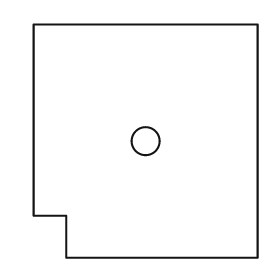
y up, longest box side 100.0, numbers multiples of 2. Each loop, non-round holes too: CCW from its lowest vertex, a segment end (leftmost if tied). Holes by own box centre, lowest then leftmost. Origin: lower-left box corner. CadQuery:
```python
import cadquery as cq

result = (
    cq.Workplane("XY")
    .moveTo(14.0, 0.0)
    .lineTo(96.0, 0.0)
    .lineTo(96.0, 100.0)
    .lineTo(0.0, 100.0)
    .lineTo(0.0, 18.0)
    .lineTo(14.0, 18.0)
    .close()
    .moveTo(48.0, 50.0)
    .circle(6.0)
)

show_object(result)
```